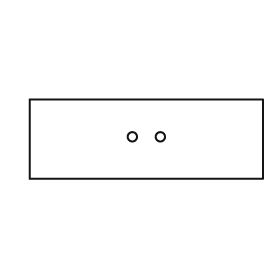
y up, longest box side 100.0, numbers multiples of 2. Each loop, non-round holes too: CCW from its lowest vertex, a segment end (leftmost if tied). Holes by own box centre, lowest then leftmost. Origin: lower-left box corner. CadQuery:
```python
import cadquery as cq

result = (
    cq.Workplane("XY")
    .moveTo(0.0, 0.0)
    .lineTo(100.0, 0.0)
    .lineTo(100.0, 34.0)
    .lineTo(0.0, 34.0)
    .close()
    .moveTo(44.0, 18.0)
    .circle(2.0)
    .moveTo(56.0, 18.0)
    .circle(2.0)
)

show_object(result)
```